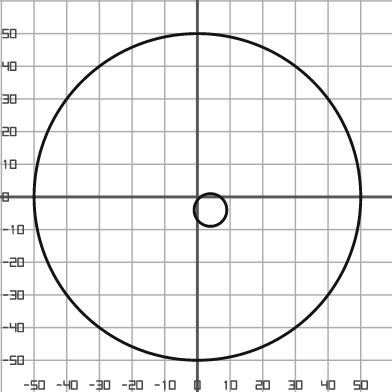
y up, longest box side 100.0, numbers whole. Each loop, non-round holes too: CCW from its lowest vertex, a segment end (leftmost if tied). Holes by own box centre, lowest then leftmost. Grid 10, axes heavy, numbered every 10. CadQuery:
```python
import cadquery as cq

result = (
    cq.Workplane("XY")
    .moveTo(0.0, 0.0)
    .circle(50.0)
    .moveTo(4.0, -4.0)
    .circle(5.0)
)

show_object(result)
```